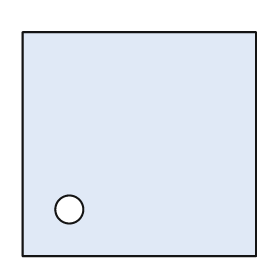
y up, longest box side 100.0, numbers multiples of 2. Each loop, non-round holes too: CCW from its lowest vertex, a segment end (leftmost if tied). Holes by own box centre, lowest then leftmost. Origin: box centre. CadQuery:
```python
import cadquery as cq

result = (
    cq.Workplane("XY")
    .moveTo(-50.0, -48.0)
    .lineTo(50.0, -48.0)
    .lineTo(50.0, 48.0)
    .lineTo(-50.0, 48.0)
    .close()
    .moveTo(-30.0, -28.0)
    .circle(6.0)
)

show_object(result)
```